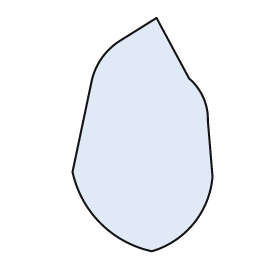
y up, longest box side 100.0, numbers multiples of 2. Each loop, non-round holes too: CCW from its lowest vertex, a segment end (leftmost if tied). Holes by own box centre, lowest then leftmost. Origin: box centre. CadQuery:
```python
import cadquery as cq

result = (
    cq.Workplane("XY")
    .moveTo(4.0, -50.0)
    .threePointArc((22.0, -38.0), (30.0, -18.0))
    .lineTo(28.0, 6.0)
    .threePointArc((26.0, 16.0), (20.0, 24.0))
    .lineTo(6.0, 50.0)
    .lineTo(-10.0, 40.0)
    .threePointArc((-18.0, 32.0), (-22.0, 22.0))
    .lineTo(-30.0, -16.0)
    .threePointArc((-18.0, -38.0), (4.0, -50.0))
    .close()
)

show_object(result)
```